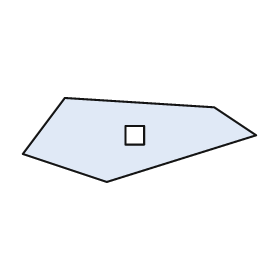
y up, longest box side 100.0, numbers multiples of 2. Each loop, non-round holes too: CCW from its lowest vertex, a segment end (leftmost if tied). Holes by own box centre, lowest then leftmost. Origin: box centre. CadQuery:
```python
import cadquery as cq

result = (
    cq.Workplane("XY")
    .moveTo(-14.0, -18.0)
    .lineTo(50.0, 2.0)
    .lineTo(32.0, 14.0)
    .lineTo(-32.0, 18.0)
    .lineTo(-50.0, -6.0)
    .close()
    .moveTo(-6.0, -2.0)
    .lineTo(2.0, -2.0)
    .lineTo(2.0, 6.0)
    .lineTo(-6.0, 6.0)
    .close()
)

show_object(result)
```